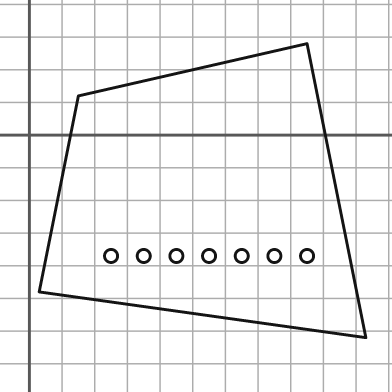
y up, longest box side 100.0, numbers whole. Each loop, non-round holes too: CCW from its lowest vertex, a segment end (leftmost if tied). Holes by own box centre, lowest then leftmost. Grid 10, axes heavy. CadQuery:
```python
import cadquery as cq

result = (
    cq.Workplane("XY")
    .moveTo(103.0, -62.0)
    .lineTo(85.0, 28.0)
    .lineTo(15.0, 12.0)
    .lineTo(3.0, -48.0)
    .close()
    .moveTo(25.0, -37.0)
    .circle(2.0)
    .moveTo(35.0, -37.0)
    .circle(2.0)
    .moveTo(45.0, -37.0)
    .circle(2.0)
    .moveTo(55.0, -37.0)
    .circle(2.0)
    .moveTo(65.0, -37.0)
    .circle(2.0)
    .moveTo(75.0, -37.0)
    .circle(2.0)
    .moveTo(85.0, -37.0)
    .circle(2.0)
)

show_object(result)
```